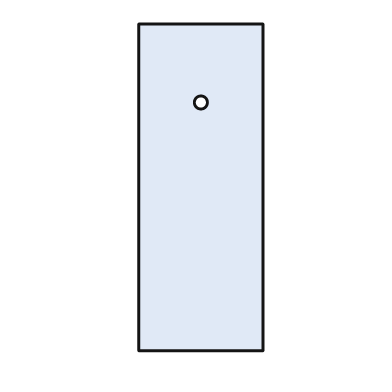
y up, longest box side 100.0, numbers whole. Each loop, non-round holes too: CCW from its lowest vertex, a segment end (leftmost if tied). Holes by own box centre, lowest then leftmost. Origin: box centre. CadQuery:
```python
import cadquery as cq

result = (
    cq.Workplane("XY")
    .moveTo(-19.0, -50.0)
    .lineTo(19.0, -50.0)
    .lineTo(19.0, 50.0)
    .lineTo(-19.0, 50.0)
    .close()
    .moveTo(0.0, 26.0)
    .circle(2.0)
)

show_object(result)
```